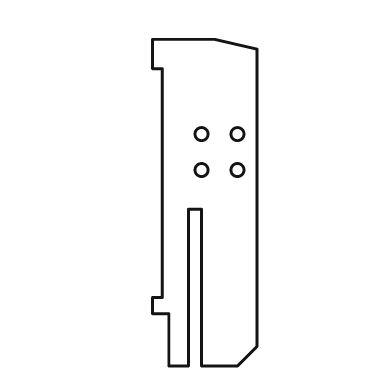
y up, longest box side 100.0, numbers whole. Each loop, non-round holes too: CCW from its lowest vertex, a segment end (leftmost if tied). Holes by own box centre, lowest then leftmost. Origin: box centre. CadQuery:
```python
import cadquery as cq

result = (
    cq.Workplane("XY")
    .moveTo(-11.0, -50.0)
    .lineTo(-5.0, -50.0)
    .lineTo(-5.0, -2.0)
    .lineTo(-1.0, -2.0)
    .lineTo(-1.0, -50.0)
    .lineTo(10.0, -50.0)
    .lineTo(16.0, -44.0)
    .lineTo(16.0, 47.0)
    .lineTo(3.0, 50.0)
    .lineTo(-16.0, 50.0)
    .lineTo(-16.0, 41.0)
    .lineTo(-13.0, 41.0)
    .lineTo(-13.0, -29.0)
    .lineTo(-16.0, -29.0)
    .lineTo(-16.0, -34.0)
    .lineTo(-11.0, -34.0)
    .close()
    .moveTo(-1.0, 10.0)
    .circle(2.0)
    .moveTo(10.0, 10.0)
    .circle(2.0)
    .moveTo(-1.0, 21.0)
    .circle(2.0)
    .moveTo(10.0, 21.0)
    .circle(2.0)
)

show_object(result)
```